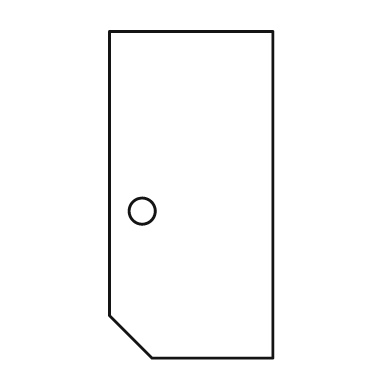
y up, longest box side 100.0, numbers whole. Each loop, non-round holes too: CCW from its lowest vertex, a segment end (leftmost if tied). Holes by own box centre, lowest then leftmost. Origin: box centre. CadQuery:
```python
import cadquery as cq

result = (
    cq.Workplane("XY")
    .moveTo(-12.0, -50.0)
    .lineTo(25.0, -50.0)
    .lineTo(25.0, 50.0)
    .lineTo(-25.0, 50.0)
    .lineTo(-25.0, -37.0)
    .close()
    .moveTo(-15.0, -5.0)
    .circle(4.0)
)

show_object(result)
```